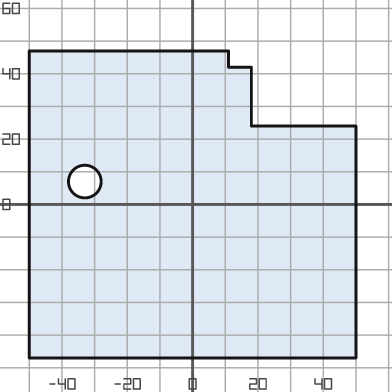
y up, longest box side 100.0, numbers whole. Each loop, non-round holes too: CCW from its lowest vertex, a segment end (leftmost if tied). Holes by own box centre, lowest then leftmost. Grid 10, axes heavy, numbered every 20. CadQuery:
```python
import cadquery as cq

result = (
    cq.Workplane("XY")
    .moveTo(-50.0, -47.0)
    .lineTo(50.0, -47.0)
    .lineTo(50.0, 24.0)
    .lineTo(18.0, 24.0)
    .lineTo(18.0, 42.0)
    .lineTo(11.0, 42.0)
    .lineTo(11.0, 47.0)
    .lineTo(-50.0, 47.0)
    .close()
    .moveTo(-33.0, 7.0)
    .circle(5.0)
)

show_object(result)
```